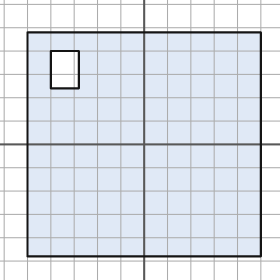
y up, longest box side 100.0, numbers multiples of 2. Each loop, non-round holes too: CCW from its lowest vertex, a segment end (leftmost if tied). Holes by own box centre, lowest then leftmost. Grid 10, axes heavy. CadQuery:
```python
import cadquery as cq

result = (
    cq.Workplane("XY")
    .moveTo(-50.0, -48.0)
    .lineTo(50.0, -48.0)
    .lineTo(50.0, 48.0)
    .lineTo(-50.0, 48.0)
    .close()
    .moveTo(-40.0, 24.0)
    .lineTo(-28.0, 24.0)
    .lineTo(-28.0, 40.0)
    .lineTo(-40.0, 40.0)
    .close()
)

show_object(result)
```